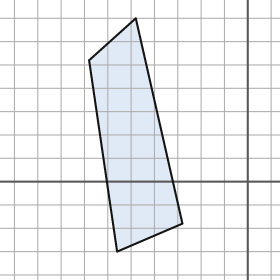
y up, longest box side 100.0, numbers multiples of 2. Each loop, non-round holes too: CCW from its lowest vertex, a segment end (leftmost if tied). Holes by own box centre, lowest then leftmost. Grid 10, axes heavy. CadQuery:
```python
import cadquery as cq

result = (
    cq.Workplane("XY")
    .moveTo(-56.0, -30.0)
    .lineTo(-28.0, -18.0)
    .lineTo(-48.0, 70.0)
    .lineTo(-68.0, 52.0)
    .close()
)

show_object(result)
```